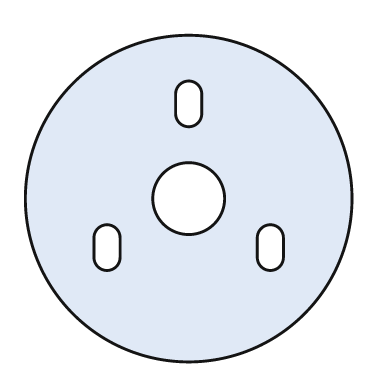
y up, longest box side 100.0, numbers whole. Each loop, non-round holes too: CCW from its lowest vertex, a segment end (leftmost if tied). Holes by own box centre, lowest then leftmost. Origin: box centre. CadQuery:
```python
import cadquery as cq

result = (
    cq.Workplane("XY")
    .moveTo(0.0, 0.0)
    .circle(50.0)
    .moveTo(-29.0, -18.0)
    .threePointArc((-25.0, -22.0), (-21.0, -18.0))
    .lineTo(-21.0, -12.0)
    .threePointArc((-25.0, -8.0), (-29.0, -12.0))
    .close()
    .moveTo(21.0, -18.0)
    .threePointArc((25.0, -22.0), (29.0, -18.0))
    .lineTo(29.0, -12.0)
    .threePointArc((25.0, -8.0), (21.0, -12.0))
    .close()
    .moveTo(0.0, 0.0)
    .circle(11.0)
    .moveTo(-4.0, 26.0)
    .threePointArc((0.0, 22.0), (4.0, 26.0))
    .lineTo(4.0, 32.0)
    .threePointArc((0.0, 36.0), (-4.0, 32.0))
    .close()
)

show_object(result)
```